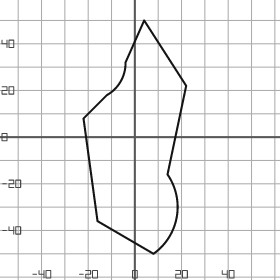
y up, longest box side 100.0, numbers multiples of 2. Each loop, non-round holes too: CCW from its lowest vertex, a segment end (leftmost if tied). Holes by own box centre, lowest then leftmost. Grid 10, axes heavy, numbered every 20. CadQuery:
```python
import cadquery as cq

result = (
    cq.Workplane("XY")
    .moveTo(8.0, -50.0)
    .threePointArc((18.0, -34.0), (14.0, -16.0))
    .lineTo(22.0, 22.0)
    .lineTo(4.0, 50.0)
    .lineTo(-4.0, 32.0)
    .threePointArc((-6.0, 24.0), (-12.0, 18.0))
    .lineTo(-22.0, 8.0)
    .lineTo(-16.0, -36.0)
    .close()
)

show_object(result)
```